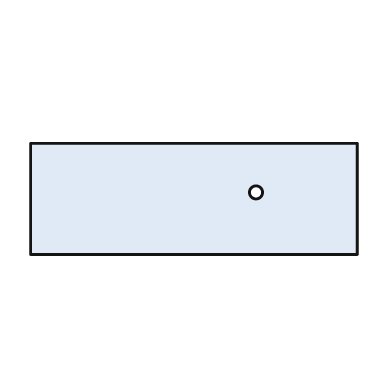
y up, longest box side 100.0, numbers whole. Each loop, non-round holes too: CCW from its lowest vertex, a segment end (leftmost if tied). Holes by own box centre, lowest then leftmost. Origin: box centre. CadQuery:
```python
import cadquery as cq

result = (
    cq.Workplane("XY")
    .moveTo(-50.0, -17.0)
    .lineTo(50.0, -17.0)
    .lineTo(50.0, 17.0)
    .lineTo(-50.0, 17.0)
    .close()
    .moveTo(19.0, 2.0)
    .circle(2.0)
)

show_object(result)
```